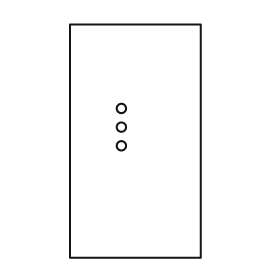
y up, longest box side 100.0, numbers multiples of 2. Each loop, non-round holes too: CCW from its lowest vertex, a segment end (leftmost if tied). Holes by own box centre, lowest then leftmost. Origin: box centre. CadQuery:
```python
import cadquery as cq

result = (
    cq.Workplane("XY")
    .moveTo(-28.0, -50.0)
    .lineTo(28.0, -50.0)
    .lineTo(28.0, 50.0)
    .lineTo(-28.0, 50.0)
    .close()
    .moveTo(-6.0, -2.0)
    .circle(2.0)
    .moveTo(-6.0, 6.0)
    .circle(2.0)
    .moveTo(-6.0, 14.0)
    .circle(2.0)
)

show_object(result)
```